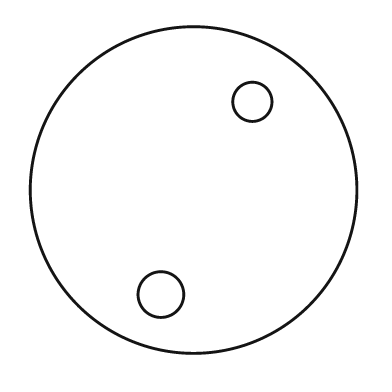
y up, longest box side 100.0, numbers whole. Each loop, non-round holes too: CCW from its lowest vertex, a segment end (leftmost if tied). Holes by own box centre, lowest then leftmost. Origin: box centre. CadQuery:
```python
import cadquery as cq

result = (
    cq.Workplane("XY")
    .moveTo(0.0, 0.0)
    .circle(50.0)
    .moveTo(-10.0, -32.0)
    .circle(7.0)
    .moveTo(18.0, 27.0)
    .circle(6.0)
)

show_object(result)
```